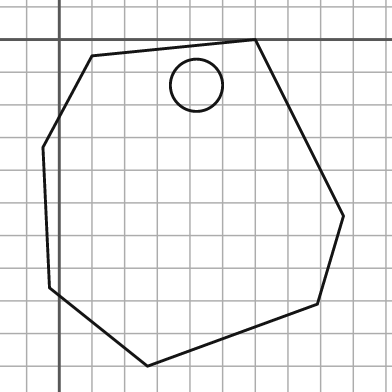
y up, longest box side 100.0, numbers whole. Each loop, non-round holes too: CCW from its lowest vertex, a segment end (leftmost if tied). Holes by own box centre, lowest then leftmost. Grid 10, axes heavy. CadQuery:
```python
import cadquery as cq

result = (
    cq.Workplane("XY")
    .moveTo(27.0, -100.0)
    .lineTo(79.0, -81.0)
    .lineTo(87.0, -54.0)
    .lineTo(60.0, 0.0)
    .lineTo(10.0, -5.0)
    .lineTo(-5.0, -33.0)
    .lineTo(-3.0, -76.0)
    .close()
    .moveTo(42.0, -14.0)
    .circle(8.0)
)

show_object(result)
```